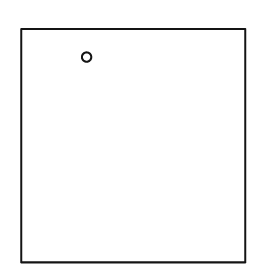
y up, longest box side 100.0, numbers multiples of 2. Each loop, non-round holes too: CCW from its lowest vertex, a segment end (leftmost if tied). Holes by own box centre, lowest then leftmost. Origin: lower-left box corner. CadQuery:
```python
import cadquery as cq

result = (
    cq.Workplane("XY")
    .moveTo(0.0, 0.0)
    .lineTo(96.0, 0.0)
    .lineTo(96.0, 100.0)
    .lineTo(0.0, 100.0)
    .close()
    .moveTo(28.0, 88.0)
    .circle(2.0)
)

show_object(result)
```